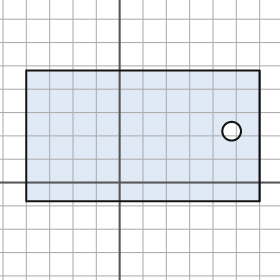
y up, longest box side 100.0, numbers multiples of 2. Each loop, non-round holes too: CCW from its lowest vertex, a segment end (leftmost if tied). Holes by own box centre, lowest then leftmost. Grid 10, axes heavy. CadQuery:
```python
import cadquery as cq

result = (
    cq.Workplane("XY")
    .moveTo(-40.0, -8.0)
    .lineTo(60.0, -8.0)
    .lineTo(60.0, 48.0)
    .lineTo(-40.0, 48.0)
    .close()
    .moveTo(48.0, 22.0)
    .circle(4.0)
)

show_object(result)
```